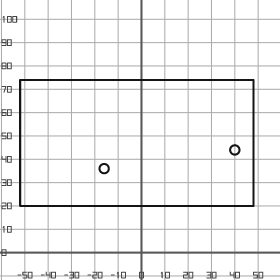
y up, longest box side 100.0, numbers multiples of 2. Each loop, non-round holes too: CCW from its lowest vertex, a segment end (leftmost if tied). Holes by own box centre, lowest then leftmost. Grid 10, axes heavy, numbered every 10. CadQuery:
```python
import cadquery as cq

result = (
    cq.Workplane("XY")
    .moveTo(-52.0, 20.0)
    .lineTo(48.0, 20.0)
    .lineTo(48.0, 74.0)
    .lineTo(-52.0, 74.0)
    .close()
    .moveTo(-16.0, 36.0)
    .circle(2.0)
    .moveTo(40.0, 44.0)
    .circle(2.0)
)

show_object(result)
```